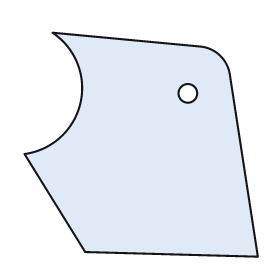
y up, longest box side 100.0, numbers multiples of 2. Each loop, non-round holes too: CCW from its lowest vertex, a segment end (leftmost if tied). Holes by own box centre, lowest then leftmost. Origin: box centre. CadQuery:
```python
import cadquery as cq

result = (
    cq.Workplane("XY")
    .moveTo(50.0, -48.0)
    .lineTo(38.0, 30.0)
    .threePointArc((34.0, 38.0), (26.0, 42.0))
    .lineTo(-38.0, 48.0)
    .threePointArc((-26.0, 18.0), (-50.0, -4.0))
    .lineTo(-24.0, -46.0)
    .close()
    .moveTo(20.0, 22.0)
    .circle(4.0)
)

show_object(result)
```